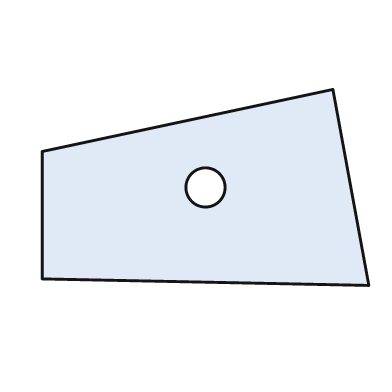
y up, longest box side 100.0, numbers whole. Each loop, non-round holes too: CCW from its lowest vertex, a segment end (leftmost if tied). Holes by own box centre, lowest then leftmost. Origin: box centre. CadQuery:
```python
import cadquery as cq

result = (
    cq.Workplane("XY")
    .moveTo(50.0, -30.0)
    .lineTo(39.0, 30.0)
    .lineTo(-50.0, 11.0)
    .lineTo(-50.0, -28.0)
    .close()
    .moveTo(0.0, 0.0)
    .circle(6.0)
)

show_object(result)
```